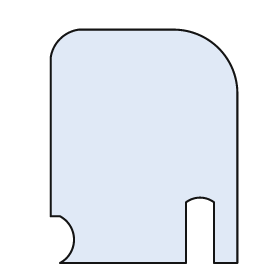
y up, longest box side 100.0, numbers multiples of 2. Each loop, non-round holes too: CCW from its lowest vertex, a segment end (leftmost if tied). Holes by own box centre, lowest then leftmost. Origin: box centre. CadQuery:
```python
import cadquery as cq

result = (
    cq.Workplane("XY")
    .moveTo(-36.0, -50.0)
    .lineTo(18.0, -50.0)
    .lineTo(18.0, -24.0)
    .threePointArc((24.0, -22.0), (30.0, -24.0))
    .lineTo(30.0, -50.0)
    .lineTo(40.0, -50.0)
    .lineTo(40.0, 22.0)
    .threePointArc((32.0, 42.0), (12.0, 50.0))
    .lineTo(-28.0, 50.0)
    .threePointArc((-36.0, 46.0), (-40.0, 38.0))
    .lineTo(-40.0, -30.0)
    .lineTo(-36.0, -30.0)
    .threePointArc((-30.0, -40.0), (-36.0, -50.0))
    .close()
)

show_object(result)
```